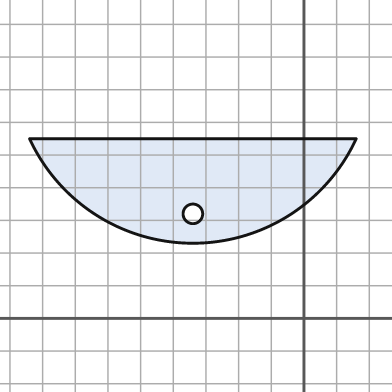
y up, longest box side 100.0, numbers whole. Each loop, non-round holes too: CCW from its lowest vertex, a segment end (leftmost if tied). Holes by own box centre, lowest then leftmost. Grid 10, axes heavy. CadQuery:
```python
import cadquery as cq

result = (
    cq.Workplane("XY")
    .moveTo(-84.0, 55.0)
    .threePointArc((-34.0, 23.0), (16.0, 55.0))
    .close()
    .moveTo(-34.0, 32.0)
    .circle(3.0)
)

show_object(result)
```